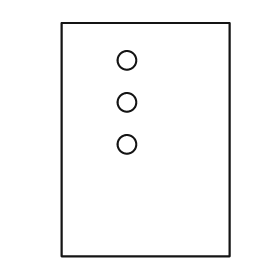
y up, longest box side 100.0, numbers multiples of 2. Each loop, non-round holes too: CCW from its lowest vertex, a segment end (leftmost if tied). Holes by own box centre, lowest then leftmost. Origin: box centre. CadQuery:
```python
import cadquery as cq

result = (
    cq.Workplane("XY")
    .moveTo(-36.0, -50.0)
    .lineTo(36.0, -50.0)
    .lineTo(36.0, 50.0)
    .lineTo(-36.0, 50.0)
    .close()
    .moveTo(-8.0, -2.0)
    .circle(4.0)
    .moveTo(-8.0, 16.0)
    .circle(4.0)
    .moveTo(-8.0, 34.0)
    .circle(4.0)
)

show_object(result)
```